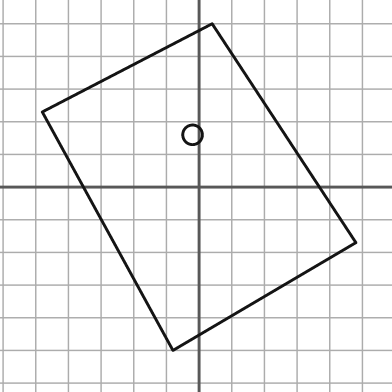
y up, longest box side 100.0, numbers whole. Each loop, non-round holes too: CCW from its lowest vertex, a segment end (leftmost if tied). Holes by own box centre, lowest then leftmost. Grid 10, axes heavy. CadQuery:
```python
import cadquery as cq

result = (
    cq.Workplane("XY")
    .moveTo(-8.0, -50.0)
    .lineTo(48.0, -17.0)
    .lineTo(4.0, 50.0)
    .lineTo(-48.0, 23.0)
    .close()
    .moveTo(-2.0, 16.0)
    .circle(3.0)
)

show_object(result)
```